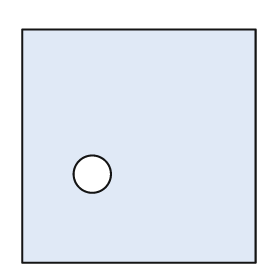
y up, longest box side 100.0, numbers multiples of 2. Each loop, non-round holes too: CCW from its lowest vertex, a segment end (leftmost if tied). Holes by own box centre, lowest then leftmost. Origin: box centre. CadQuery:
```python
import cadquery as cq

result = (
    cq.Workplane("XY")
    .moveTo(-50.0, -50.0)
    .lineTo(50.0, -50.0)
    .lineTo(50.0, 50.0)
    .lineTo(-50.0, 50.0)
    .close()
    .moveTo(-20.0, -12.0)
    .circle(8.0)
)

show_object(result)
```